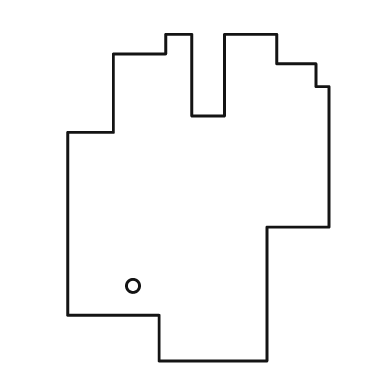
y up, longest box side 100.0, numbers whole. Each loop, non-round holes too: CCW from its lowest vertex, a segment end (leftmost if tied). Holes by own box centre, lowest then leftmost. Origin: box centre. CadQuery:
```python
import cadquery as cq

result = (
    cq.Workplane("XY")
    .moveTo(-12.0, -50.0)
    .lineTo(21.0, -50.0)
    .lineTo(21.0, -9.0)
    .lineTo(40.0, -9.0)
    .lineTo(40.0, 34.0)
    .lineTo(36.0, 34.0)
    .lineTo(36.0, 41.0)
    .lineTo(24.0, 41.0)
    .lineTo(24.0, 50.0)
    .lineTo(8.0, 50.0)
    .lineTo(8.0, 25.0)
    .lineTo(-2.0, 25.0)
    .lineTo(-2.0, 50.0)
    .lineTo(-10.0, 50.0)
    .lineTo(-10.0, 44.0)
    .lineTo(-26.0, 44.0)
    .lineTo(-26.0, 20.0)
    .lineTo(-40.0, 20.0)
    .lineTo(-40.0, -36.0)
    .lineTo(-12.0, -36.0)
    .close()
    .moveTo(-20.0, -27.0)
    .circle(2.0)
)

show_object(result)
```